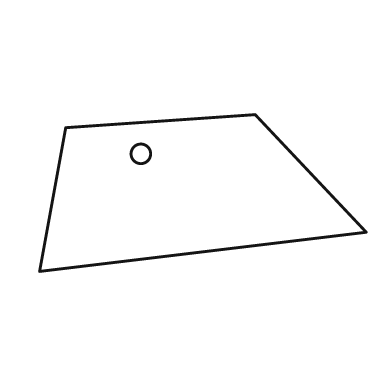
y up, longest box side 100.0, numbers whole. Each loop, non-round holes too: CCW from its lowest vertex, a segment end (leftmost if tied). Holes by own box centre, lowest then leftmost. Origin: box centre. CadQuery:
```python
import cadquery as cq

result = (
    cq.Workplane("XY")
    .moveTo(-50.0, -24.0)
    .lineTo(50.0, -12.0)
    .lineTo(16.0, 24.0)
    .lineTo(-42.0, 20.0)
    .close()
    .moveTo(-19.0, 12.0)
    .circle(3.0)
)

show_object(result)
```